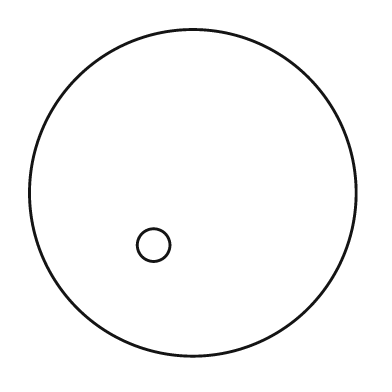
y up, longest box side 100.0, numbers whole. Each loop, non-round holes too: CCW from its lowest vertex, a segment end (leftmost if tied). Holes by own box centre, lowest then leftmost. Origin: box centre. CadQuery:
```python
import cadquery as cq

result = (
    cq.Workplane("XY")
    .moveTo(0.0, 0.0)
    .circle(50.0)
    .moveTo(-12.0, -16.0)
    .circle(5.0)
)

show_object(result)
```